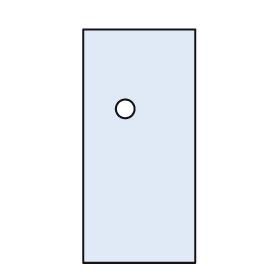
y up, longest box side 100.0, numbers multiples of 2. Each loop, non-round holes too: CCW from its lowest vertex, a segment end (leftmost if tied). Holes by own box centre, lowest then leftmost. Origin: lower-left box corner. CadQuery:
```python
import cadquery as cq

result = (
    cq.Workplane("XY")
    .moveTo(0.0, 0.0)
    .lineTo(48.0, 0.0)
    .lineTo(48.0, 100.0)
    .lineTo(0.0, 100.0)
    .close()
    .moveTo(18.0, 66.0)
    .circle(4.0)
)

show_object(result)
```